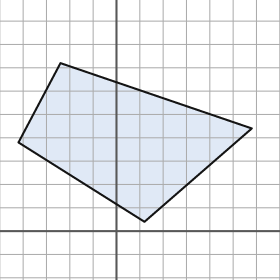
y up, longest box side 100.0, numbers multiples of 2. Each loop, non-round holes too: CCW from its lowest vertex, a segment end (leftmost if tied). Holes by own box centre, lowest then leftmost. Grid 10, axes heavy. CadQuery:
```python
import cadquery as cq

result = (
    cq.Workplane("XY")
    .moveTo(12.0, 4.0)
    .lineTo(58.0, 44.0)
    .lineTo(-24.0, 72.0)
    .lineTo(-42.0, 38.0)
    .close()
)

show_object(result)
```